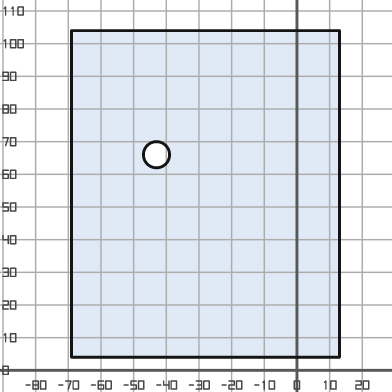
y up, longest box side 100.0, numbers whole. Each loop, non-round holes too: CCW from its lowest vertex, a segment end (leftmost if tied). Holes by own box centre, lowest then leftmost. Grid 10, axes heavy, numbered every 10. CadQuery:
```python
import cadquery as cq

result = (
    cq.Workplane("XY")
    .moveTo(-69.0, 4.0)
    .lineTo(13.0, 4.0)
    .lineTo(13.0, 104.0)
    .lineTo(-69.0, 104.0)
    .close()
    .moveTo(-43.0, 66.0)
    .circle(4.0)
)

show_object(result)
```